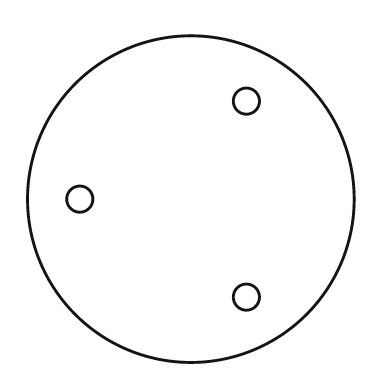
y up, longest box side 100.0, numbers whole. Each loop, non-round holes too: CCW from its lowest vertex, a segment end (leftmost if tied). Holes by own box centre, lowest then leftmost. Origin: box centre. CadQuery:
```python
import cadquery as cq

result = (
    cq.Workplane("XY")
    .moveTo(0.0, 0.0)
    .circle(50.0)
    .moveTo(17.0, -30.0)
    .circle(4.0)
    .moveTo(-34.0, 0.0)
    .circle(4.0)
    .moveTo(17.0, 30.0)
    .circle(4.0)
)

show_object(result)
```